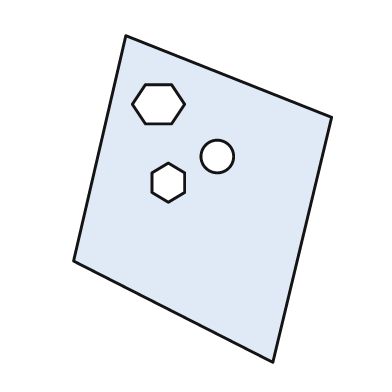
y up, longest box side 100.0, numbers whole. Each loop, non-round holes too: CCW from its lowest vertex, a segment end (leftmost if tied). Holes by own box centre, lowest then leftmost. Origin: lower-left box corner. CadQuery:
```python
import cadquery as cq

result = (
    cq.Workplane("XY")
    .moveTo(61.0, 0.0)
    .lineTo(79.0, 75.0)
    .lineTo(16.0, 100.0)
    .lineTo(0.0, 31.0)
    .close()
    .moveTo(29.0, 49.0)
    .lineTo(34.0, 52.0)
    .lineTo(34.0, 58.0)
    .lineTo(29.0, 61.0)
    .lineTo(24.0, 58.0)
    .lineTo(24.0, 52.0)
    .close()
    .moveTo(44.0, 63.0)
    .circle(5.0)
    .moveTo(22.0, 73.0)
    .lineTo(30.0, 73.0)
    .lineTo(34.0, 79.0)
    .lineTo(30.0, 85.0)
    .lineTo(22.0, 85.0)
    .lineTo(18.0, 79.0)
    .close()
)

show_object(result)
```